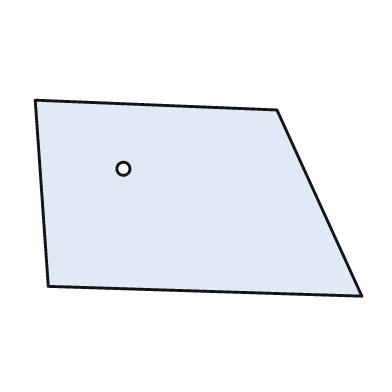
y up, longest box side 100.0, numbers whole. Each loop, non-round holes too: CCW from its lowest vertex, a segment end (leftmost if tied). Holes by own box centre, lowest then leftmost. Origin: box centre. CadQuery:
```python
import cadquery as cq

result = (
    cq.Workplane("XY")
    .moveTo(50.0, -30.0)
    .lineTo(24.0, 27.0)
    .lineTo(-50.0, 30.0)
    .lineTo(-46.0, -27.0)
    .close()
    .moveTo(-23.0, 9.0)
    .circle(2.0)
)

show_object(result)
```